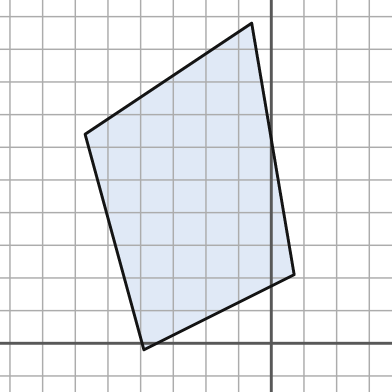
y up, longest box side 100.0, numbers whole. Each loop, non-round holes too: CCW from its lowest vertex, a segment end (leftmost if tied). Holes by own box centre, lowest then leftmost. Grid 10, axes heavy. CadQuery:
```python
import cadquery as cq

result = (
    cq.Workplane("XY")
    .moveTo(-39.0, -2.0)
    .lineTo(7.0, 21.0)
    .lineTo(-6.0, 98.0)
    .lineTo(-57.0, 64.0)
    .close()
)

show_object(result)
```